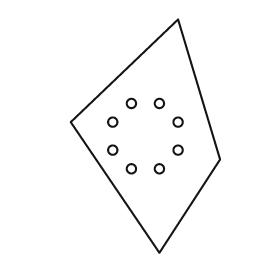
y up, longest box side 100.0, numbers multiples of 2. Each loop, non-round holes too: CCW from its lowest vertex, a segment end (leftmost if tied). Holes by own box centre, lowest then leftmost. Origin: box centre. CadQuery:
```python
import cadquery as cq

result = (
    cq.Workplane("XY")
    .moveTo(6.0, -50.0)
    .lineTo(32.0, -10.0)
    .lineTo(14.0, 50.0)
    .lineTo(-32.0, 6.0)
    .close()
    .moveTo(-6.0, -14.0)
    .circle(2.0)
    .moveTo(6.0, -14.0)
    .circle(2.0)
    .moveTo(-14.0, -6.0)
    .circle(2.0)
    .moveTo(14.0, -6.0)
    .circle(2.0)
    .moveTo(-14.0, 6.0)
    .circle(2.0)
    .moveTo(14.0, 6.0)
    .circle(2.0)
    .moveTo(-6.0, 14.0)
    .circle(2.0)
    .moveTo(6.0, 14.0)
    .circle(2.0)
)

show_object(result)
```